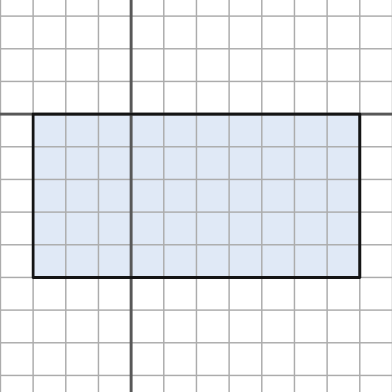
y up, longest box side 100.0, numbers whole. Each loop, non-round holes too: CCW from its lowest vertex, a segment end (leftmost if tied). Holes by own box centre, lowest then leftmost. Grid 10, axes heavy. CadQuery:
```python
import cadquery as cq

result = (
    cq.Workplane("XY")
    .moveTo(-30.0, -50.0)
    .lineTo(70.0, -50.0)
    .lineTo(70.0, 0.0)
    .lineTo(-30.0, 0.0)
    .close()
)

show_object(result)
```